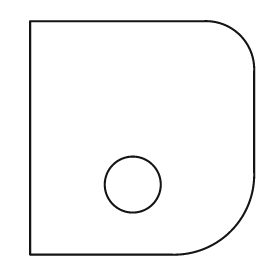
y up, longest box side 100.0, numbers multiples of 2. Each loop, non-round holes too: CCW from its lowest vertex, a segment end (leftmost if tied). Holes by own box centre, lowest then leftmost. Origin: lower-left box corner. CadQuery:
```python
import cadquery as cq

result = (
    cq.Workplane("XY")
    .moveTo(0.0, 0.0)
    .lineTo(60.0, 0.0)
    .threePointArc((86.0, 10.0), (96.0, 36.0))
    .lineTo(96.0, 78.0)
    .threePointArc((90.0, 94.0), (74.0, 100.0))
    .lineTo(0.0, 100.0)
    .close()
    .moveTo(44.0, 30.0)
    .circle(12.0)
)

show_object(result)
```